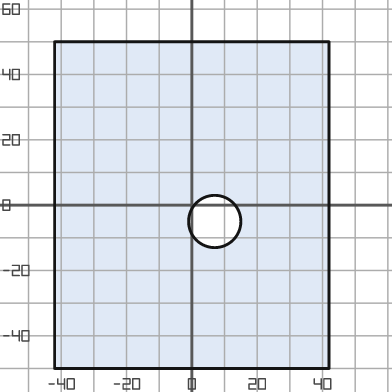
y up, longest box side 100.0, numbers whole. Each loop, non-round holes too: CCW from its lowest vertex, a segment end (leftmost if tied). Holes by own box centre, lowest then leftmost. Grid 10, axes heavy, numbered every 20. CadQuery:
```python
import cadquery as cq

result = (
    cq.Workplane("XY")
    .moveTo(-42.0, -50.0)
    .lineTo(42.0, -50.0)
    .lineTo(42.0, 50.0)
    .lineTo(-42.0, 50.0)
    .close()
    .moveTo(7.0, -5.0)
    .circle(8.0)
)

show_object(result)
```